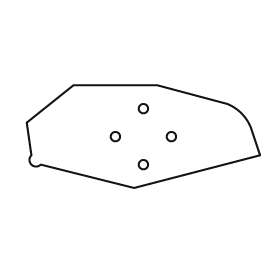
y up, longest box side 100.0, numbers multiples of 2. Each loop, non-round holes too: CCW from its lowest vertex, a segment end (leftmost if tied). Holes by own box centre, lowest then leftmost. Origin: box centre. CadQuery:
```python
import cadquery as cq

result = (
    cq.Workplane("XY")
    .moveTo(-4.0, -22.0)
    .lineTo(50.0, -8.0)
    .lineTo(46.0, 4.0)
    .threePointArc((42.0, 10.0), (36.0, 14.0))
    .lineTo(6.0, 22.0)
    .lineTo(-30.0, 22.0)
    .lineTo(-50.0, 6.0)
    .lineTo(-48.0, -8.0)
    .threePointArc((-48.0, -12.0), (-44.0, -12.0))
    .close()
    .moveTo(0.0, -12.0)
    .circle(2.0)
    .moveTo(-12.0, 0.0)
    .circle(2.0)
    .moveTo(12.0, 0.0)
    .circle(2.0)
    .moveTo(0.0, 12.0)
    .circle(2.0)
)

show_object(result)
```